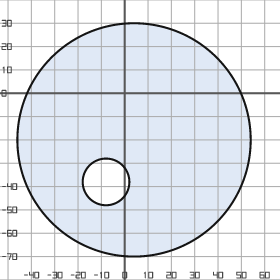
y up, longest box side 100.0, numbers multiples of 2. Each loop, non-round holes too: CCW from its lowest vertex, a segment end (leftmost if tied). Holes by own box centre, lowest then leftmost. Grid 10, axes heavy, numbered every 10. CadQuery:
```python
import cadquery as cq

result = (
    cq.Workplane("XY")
    .moveTo(4.0, -20.0)
    .circle(50.0)
    .moveTo(-8.0, -38.0)
    .circle(10.0)
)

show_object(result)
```